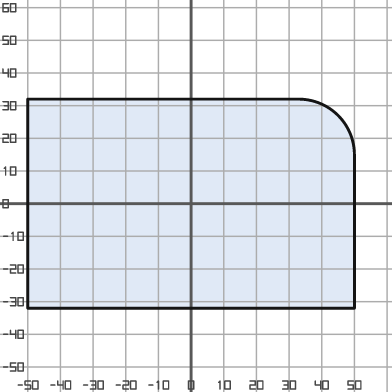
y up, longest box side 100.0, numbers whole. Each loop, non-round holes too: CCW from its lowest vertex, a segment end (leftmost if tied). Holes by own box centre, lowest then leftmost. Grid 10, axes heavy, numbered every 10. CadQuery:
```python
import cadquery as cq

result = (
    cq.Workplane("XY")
    .moveTo(-50.0, -32.0)
    .lineTo(50.0, -32.0)
    .lineTo(50.0, 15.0)
    .threePointArc((45.0, 27.0), (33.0, 32.0))
    .lineTo(-50.0, 32.0)
    .close()
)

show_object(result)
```